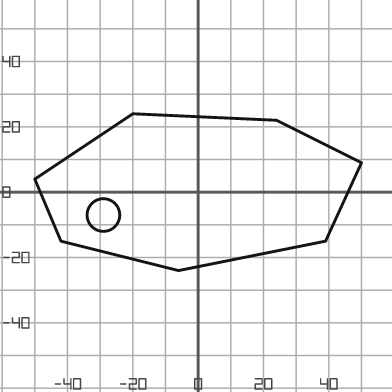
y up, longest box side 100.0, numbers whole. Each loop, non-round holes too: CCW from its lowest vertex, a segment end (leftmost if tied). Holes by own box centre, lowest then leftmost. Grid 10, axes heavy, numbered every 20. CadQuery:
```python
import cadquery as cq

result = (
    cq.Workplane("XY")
    .moveTo(-6.0, -24.0)
    .lineTo(39.0, -15.0)
    .lineTo(50.0, 9.0)
    .lineTo(24.0, 22.0)
    .lineTo(-20.0, 24.0)
    .lineTo(-50.0, 4.0)
    .lineTo(-42.0, -15.0)
    .close()
    .moveTo(-29.0, -7.0)
    .circle(5.0)
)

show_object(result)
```